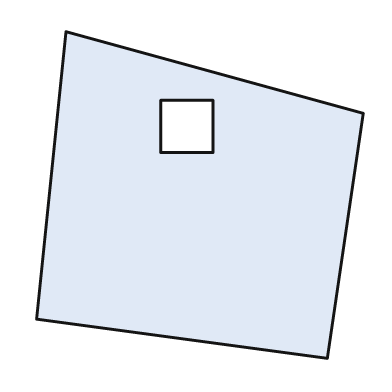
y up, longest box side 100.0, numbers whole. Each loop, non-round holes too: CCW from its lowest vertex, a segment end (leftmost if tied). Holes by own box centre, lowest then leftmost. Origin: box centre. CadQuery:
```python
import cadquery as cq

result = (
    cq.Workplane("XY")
    .moveTo(39.0, -50.0)
    .lineTo(50.0, 25.0)
    .lineTo(-41.0, 50.0)
    .lineTo(-50.0, -38.0)
    .close()
    .moveTo(-12.0, 13.0)
    .lineTo(4.0, 13.0)
    .lineTo(4.0, 29.0)
    .lineTo(-12.0, 29.0)
    .close()
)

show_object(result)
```